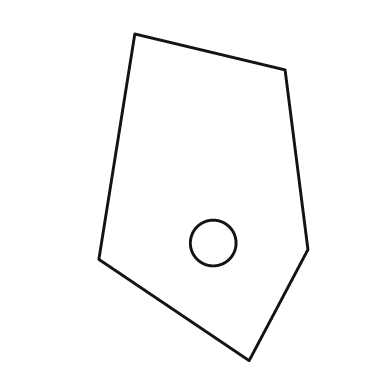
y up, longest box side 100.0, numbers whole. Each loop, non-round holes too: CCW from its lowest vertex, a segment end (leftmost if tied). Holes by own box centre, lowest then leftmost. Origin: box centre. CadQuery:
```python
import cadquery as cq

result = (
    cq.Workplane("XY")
    .moveTo(14.0, -50.0)
    .lineTo(32.0, -16.0)
    .lineTo(25.0, 39.0)
    .lineTo(-21.0, 50.0)
    .lineTo(-32.0, -19.0)
    .close()
    .moveTo(3.0, -14.0)
    .circle(7.0)
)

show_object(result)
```